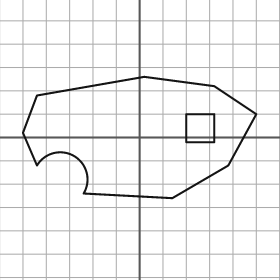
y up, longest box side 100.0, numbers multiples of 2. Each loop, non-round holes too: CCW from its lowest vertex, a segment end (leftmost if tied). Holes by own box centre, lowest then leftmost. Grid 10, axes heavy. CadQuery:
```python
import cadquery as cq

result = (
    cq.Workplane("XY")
    .moveTo(14.0, -26.0)
    .lineTo(38.0, -12.0)
    .lineTo(50.0, 10.0)
    .lineTo(32.0, 22.0)
    .lineTo(2.0, 26.0)
    .lineTo(-44.0, 18.0)
    .lineTo(-50.0, 2.0)
    .lineTo(-44.0, -12.0)
    .threePointArc((-28.0, -8.0), (-24.0, -24.0))
    .close()
    .moveTo(20.0, -2.0)
    .lineTo(32.0, -2.0)
    .lineTo(32.0, 10.0)
    .lineTo(20.0, 10.0)
    .close()
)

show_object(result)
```